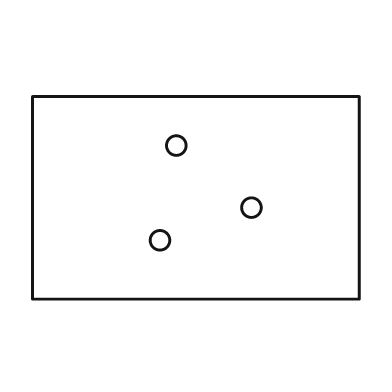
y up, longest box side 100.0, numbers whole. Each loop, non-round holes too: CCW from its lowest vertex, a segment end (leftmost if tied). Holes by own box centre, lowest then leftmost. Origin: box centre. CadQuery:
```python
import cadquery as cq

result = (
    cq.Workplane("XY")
    .moveTo(-50.0, -31.0)
    .lineTo(50.0, -31.0)
    .lineTo(50.0, 31.0)
    .lineTo(-50.0, 31.0)
    .close()
    .moveTo(-11.0, -13.0)
    .circle(3.0)
    .moveTo(17.0, -3.0)
    .circle(3.0)
    .moveTo(-6.0, 16.0)
    .circle(3.0)
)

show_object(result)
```